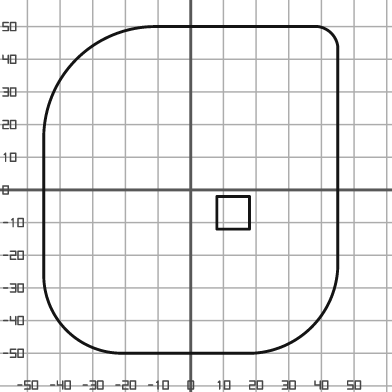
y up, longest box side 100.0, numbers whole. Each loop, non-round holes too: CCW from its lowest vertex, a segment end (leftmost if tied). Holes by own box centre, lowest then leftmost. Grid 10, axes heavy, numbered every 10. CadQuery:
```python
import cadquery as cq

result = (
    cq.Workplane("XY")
    .moveTo(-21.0, -50.0)
    .lineTo(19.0, -50.0)
    .threePointArc((37.0, -42.0), (45.0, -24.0))
    .lineTo(45.0, 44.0)
    .threePointArc((43.0, 48.0), (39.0, 50.0))
    .lineTo(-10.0, 50.0)
    .threePointArc((-35.0, 40.0), (-45.0, 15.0))
    .lineTo(-45.0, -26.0)
    .threePointArc((-38.0, -43.0), (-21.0, -50.0))
    .close()
    .moveTo(8.0, -12.0)
    .lineTo(18.0, -12.0)
    .lineTo(18.0, -2.0)
    .lineTo(8.0, -2.0)
    .close()
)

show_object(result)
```